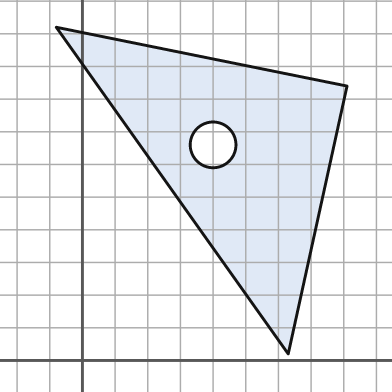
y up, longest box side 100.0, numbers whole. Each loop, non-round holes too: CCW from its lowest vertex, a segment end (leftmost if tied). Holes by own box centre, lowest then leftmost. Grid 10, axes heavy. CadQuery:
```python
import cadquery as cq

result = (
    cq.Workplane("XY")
    .moveTo(63.0, 2.0)
    .lineTo(81.0, 84.0)
    .lineTo(-8.0, 102.0)
    .close()
    .moveTo(40.0, 66.0)
    .circle(7.0)
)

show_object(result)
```